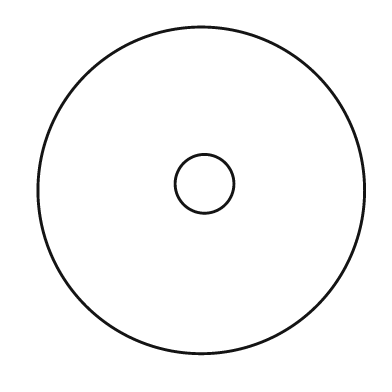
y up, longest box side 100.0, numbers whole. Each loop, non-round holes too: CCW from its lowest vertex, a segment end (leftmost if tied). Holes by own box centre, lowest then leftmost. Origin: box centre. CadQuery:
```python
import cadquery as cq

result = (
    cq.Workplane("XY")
    .moveTo(0.0, 0.0)
    .circle(50.0)
    .moveTo(1.0, 2.0)
    .circle(9.0)
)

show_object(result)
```